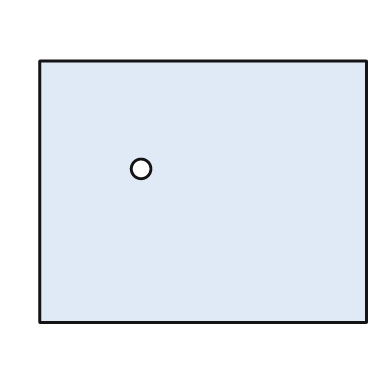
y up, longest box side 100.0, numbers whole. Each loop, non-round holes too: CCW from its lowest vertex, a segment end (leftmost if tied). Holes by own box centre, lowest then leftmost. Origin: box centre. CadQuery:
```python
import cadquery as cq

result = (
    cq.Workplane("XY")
    .moveTo(-50.0, -40.0)
    .lineTo(50.0, -40.0)
    .lineTo(50.0, 40.0)
    .lineTo(-50.0, 40.0)
    .close()
    .moveTo(-19.0, 7.0)
    .circle(3.0)
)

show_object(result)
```